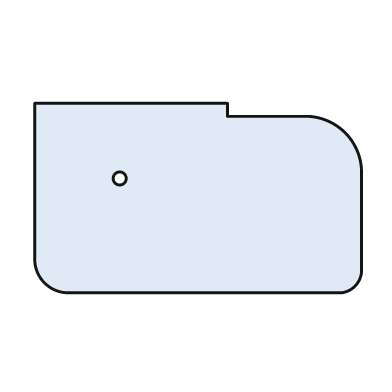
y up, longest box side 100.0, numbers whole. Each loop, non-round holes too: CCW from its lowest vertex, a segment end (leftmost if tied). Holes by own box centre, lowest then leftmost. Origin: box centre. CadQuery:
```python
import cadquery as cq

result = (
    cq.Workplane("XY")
    .moveTo(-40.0, -29.0)
    .lineTo(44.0, -29.0)
    .threePointArc((48.0, -27.0), (50.0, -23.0))
    .lineTo(50.0, 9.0)
    .threePointArc((45.0, 20.0), (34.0, 25.0))
    .lineTo(9.0, 25.0)
    .lineTo(9.0, 29.0)
    .lineTo(-50.0, 29.0)
    .lineTo(-50.0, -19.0)
    .threePointArc((-47.0, -26.0), (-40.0, -29.0))
    .close()
    .moveTo(-24.0, 6.0)
    .circle(2.0)
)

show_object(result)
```